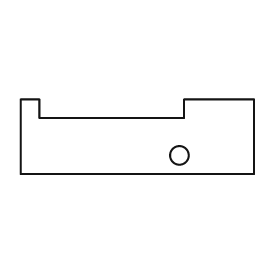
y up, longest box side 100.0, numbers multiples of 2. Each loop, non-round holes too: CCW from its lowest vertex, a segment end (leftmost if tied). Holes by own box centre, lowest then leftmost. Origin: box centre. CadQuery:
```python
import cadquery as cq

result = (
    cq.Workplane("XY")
    .moveTo(-50.0, -16.0)
    .lineTo(50.0, -16.0)
    .lineTo(50.0, 16.0)
    .lineTo(20.0, 16.0)
    .lineTo(20.0, 8.0)
    .lineTo(-42.0, 8.0)
    .lineTo(-42.0, 16.0)
    .lineTo(-50.0, 16.0)
    .close()
    .moveTo(18.0, -8.0)
    .circle(4.0)
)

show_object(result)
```